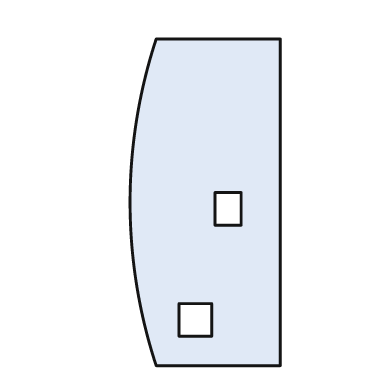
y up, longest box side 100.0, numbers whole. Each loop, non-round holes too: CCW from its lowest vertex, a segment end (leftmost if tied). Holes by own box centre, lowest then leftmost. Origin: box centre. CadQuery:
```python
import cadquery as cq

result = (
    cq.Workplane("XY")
    .moveTo(-15.0, -50.0)
    .lineTo(23.0, -50.0)
    .lineTo(23.0, 50.0)
    .lineTo(-15.0, 50.0)
    .threePointArc((-23.0, 0.0), (-15.0, -50.0))
    .close()
    .moveTo(-8.0, -41.0)
    .lineTo(2.0, -41.0)
    .lineTo(2.0, -31.0)
    .lineTo(-8.0, -31.0)
    .close()
    .moveTo(3.0, -7.0)
    .lineTo(11.0, -7.0)
    .lineTo(11.0, 3.0)
    .lineTo(3.0, 3.0)
    .close()
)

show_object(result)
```